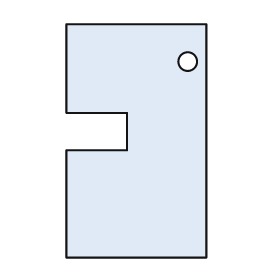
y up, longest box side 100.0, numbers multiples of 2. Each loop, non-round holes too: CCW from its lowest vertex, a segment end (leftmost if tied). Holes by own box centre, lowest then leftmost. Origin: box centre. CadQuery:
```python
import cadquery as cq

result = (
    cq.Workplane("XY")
    .moveTo(-30.0, -50.0)
    .lineTo(30.0, -50.0)
    .lineTo(30.0, 50.0)
    .lineTo(-30.0, 50.0)
    .lineTo(-30.0, 12.0)
    .lineTo(-4.0, 12.0)
    .lineTo(-4.0, -4.0)
    .lineTo(-30.0, -4.0)
    .close()
    .moveTo(22.0, 34.0)
    .circle(4.0)
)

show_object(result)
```